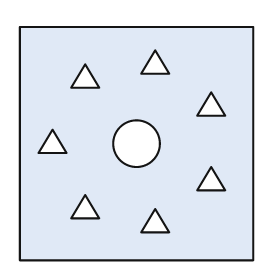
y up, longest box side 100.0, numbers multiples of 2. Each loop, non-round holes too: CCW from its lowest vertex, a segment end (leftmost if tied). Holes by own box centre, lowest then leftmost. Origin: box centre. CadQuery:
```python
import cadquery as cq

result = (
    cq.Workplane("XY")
    .moveTo(-50.0, -50.0)
    .lineTo(50.0, -50.0)
    .lineTo(50.0, 50.0)
    .lineTo(-50.0, 50.0)
    .close()
    .moveTo(2.0, -38.0)
    .lineTo(14.0, -38.0)
    .lineTo(8.0, -28.0)
    .close()
    .moveTo(-28.0, -32.0)
    .lineTo(-16.0, -32.0)
    .lineTo(-22.0, -22.0)
    .close()
    .moveTo(26.0, -20.0)
    .lineTo(38.0, -20.0)
    .lineTo(32.0, -10.0)
    .close()
    .moveTo(0.0, 0.0)
    .circle(10.0)
    .moveTo(-42.0, -4.0)
    .lineTo(-30.0, -4.0)
    .lineTo(-36.0, 6.0)
    .close()
    .moveTo(26.0, 12.0)
    .lineTo(38.0, 12.0)
    .lineTo(32.0, 22.0)
    .close()
    .moveTo(-28.0, 24.0)
    .lineTo(-16.0, 24.0)
    .lineTo(-22.0, 34.0)
    .close()
    .moveTo(2.0, 30.0)
    .lineTo(14.0, 30.0)
    .lineTo(8.0, 40.0)
    .close()
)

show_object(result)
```